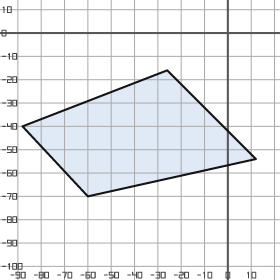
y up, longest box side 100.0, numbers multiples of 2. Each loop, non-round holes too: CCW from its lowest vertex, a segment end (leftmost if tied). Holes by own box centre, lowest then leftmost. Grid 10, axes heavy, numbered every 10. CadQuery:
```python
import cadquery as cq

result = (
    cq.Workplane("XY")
    .moveTo(-60.0, -70.0)
    .lineTo(12.0, -54.0)
    .lineTo(-26.0, -16.0)
    .lineTo(-88.0, -40.0)
    .close()
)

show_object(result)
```